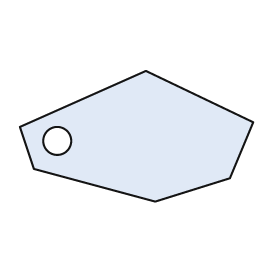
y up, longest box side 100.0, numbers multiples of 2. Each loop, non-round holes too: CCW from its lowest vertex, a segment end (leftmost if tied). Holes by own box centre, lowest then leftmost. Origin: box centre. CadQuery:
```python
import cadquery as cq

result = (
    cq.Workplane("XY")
    .moveTo(8.0, -28.0)
    .lineTo(40.0, -18.0)
    .lineTo(50.0, 6.0)
    .lineTo(4.0, 28.0)
    .lineTo(-50.0, 4.0)
    .lineTo(-44.0, -14.0)
    .close()
    .moveTo(-34.0, -2.0)
    .circle(6.0)
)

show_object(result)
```